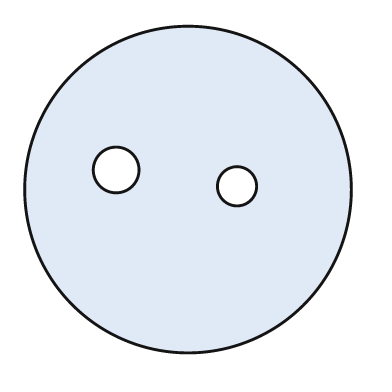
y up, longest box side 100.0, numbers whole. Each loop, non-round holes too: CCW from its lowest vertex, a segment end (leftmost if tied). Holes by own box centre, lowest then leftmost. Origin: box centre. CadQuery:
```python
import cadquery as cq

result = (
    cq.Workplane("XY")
    .moveTo(0.0, 0.0)
    .circle(50.0)
    .moveTo(15.0, 1.0)
    .circle(6.0)
    .moveTo(-22.0, 6.0)
    .circle(7.0)
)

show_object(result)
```